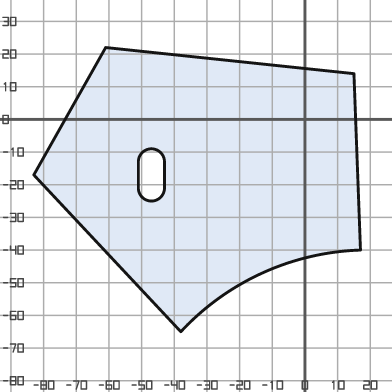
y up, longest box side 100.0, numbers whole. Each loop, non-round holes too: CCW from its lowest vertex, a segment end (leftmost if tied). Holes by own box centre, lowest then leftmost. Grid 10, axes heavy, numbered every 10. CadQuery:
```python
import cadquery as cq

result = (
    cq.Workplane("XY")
    .moveTo(-38.0, -65.0)
    .threePointArc((-13.0, -47.0), (17.0, -40.0))
    .lineTo(15.0, 14.0)
    .lineTo(-61.0, 22.0)
    .lineTo(-83.0, -17.0)
    .close()
    .moveTo(-51.0, -21.0)
    .threePointArc((-47.0, -25.0), (-43.0, -21.0))
    .lineTo(-43.0, -13.0)
    .threePointArc((-47.0, -9.0), (-51.0, -13.0))
    .close()
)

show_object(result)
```